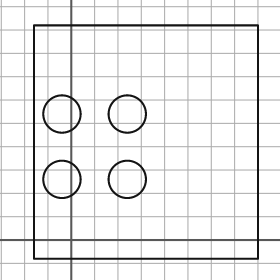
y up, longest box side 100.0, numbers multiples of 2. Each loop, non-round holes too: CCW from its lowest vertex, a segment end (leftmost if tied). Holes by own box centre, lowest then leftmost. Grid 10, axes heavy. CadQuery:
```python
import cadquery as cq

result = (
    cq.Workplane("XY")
    .moveTo(-16.0, -8.0)
    .lineTo(80.0, -8.0)
    .lineTo(80.0, 92.0)
    .lineTo(-16.0, 92.0)
    .close()
    .moveTo(-4.0, 26.0)
    .circle(8.0)
    .moveTo(24.0, 26.0)
    .circle(8.0)
    .moveTo(-4.0, 54.0)
    .circle(8.0)
    .moveTo(24.0, 54.0)
    .circle(8.0)
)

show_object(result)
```